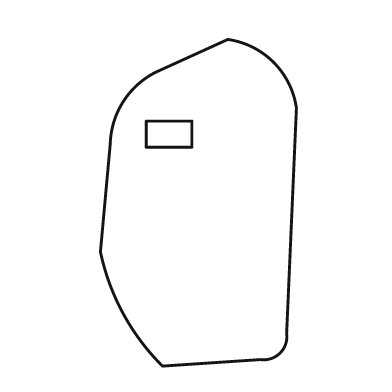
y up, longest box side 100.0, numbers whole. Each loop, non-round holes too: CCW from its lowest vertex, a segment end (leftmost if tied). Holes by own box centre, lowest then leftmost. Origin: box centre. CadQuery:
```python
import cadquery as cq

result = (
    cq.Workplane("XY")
    .moveTo(-11.0, -50.0)
    .lineTo(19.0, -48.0)
    .threePointArc((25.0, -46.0), (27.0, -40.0))
    .lineTo(30.0, 29.0)
    .threePointArc((23.0, 43.0), (9.0, 50.0))
    .lineTo(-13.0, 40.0)
    .threePointArc((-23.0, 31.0), (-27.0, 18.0))
    .lineTo(-30.0, -15.0)
    .threePointArc((-23.0, -34.0), (-11.0, -50.0))
    .close()
    .moveTo(-16.0, 17.0)
    .lineTo(-2.0, 17.0)
    .lineTo(-2.0, 25.0)
    .lineTo(-16.0, 25.0)
    .close()
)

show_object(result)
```